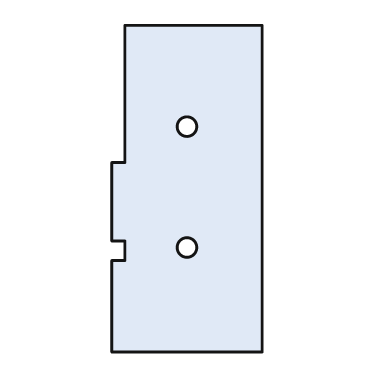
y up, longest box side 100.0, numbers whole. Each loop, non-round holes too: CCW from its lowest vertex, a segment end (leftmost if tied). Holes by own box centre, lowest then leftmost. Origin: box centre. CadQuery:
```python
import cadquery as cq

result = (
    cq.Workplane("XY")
    .moveTo(-23.0, -50.0)
    .lineTo(23.0, -50.0)
    .lineTo(23.0, 50.0)
    .lineTo(-19.0, 50.0)
    .lineTo(-19.0, 8.0)
    .lineTo(-23.0, 8.0)
    .lineTo(-23.0, -16.0)
    .lineTo(-19.0, -16.0)
    .lineTo(-19.0, -22.0)
    .lineTo(-23.0, -22.0)
    .close()
    .moveTo(0.0, -18.0)
    .circle(3.0)
    .moveTo(0.0, 19.0)
    .circle(3.0)
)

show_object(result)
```